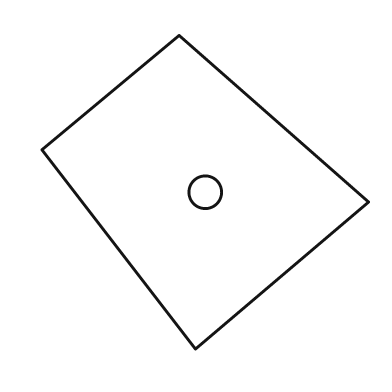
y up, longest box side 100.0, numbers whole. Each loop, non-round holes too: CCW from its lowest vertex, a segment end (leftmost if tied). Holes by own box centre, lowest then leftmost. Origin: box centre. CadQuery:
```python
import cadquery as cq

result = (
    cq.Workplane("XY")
    .moveTo(-3.0, -48.0)
    .lineTo(50.0, -3.0)
    .lineTo(-8.0, 48.0)
    .lineTo(-50.0, 13.0)
    .close()
    .moveTo(0.0, 0.0)
    .circle(5.0)
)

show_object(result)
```